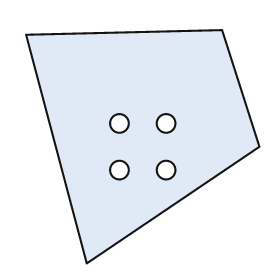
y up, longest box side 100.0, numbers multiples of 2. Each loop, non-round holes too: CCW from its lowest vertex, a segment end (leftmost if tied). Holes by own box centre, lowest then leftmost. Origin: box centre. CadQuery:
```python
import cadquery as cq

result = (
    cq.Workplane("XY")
    .moveTo(-24.0, -50.0)
    .lineTo(50.0, 0.0)
    .lineTo(34.0, 50.0)
    .lineTo(-50.0, 48.0)
    .close()
    .moveTo(-10.0, -10.0)
    .circle(4.0)
    .moveTo(10.0, -10.0)
    .circle(4.0)
    .moveTo(-10.0, 10.0)
    .circle(4.0)
    .moveTo(10.0, 10.0)
    .circle(4.0)
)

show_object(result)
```